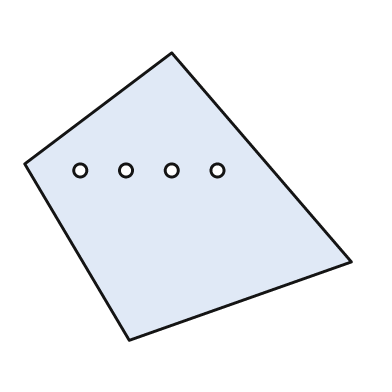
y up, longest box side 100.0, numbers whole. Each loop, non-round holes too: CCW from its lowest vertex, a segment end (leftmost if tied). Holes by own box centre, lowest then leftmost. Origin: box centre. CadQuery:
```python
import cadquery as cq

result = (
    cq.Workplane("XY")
    .moveTo(-18.0, -44.0)
    .lineTo(50.0, -20.0)
    .lineTo(-5.0, 44.0)
    .lineTo(-50.0, 10.0)
    .close()
    .moveTo(-33.0, 8.0)
    .circle(2.0)
    .moveTo(-19.0, 8.0)
    .circle(2.0)
    .moveTo(-5.0, 8.0)
    .circle(2.0)
    .moveTo(9.0, 8.0)
    .circle(2.0)
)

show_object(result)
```